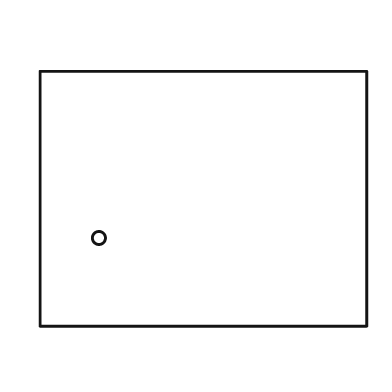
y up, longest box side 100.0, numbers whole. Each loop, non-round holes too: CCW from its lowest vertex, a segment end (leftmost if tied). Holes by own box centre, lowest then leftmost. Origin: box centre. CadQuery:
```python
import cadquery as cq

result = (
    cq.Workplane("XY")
    .moveTo(-50.0, -39.0)
    .lineTo(50.0, -39.0)
    .lineTo(50.0, 39.0)
    .lineTo(-50.0, 39.0)
    .close()
    .moveTo(-32.0, -12.0)
    .circle(2.0)
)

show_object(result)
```